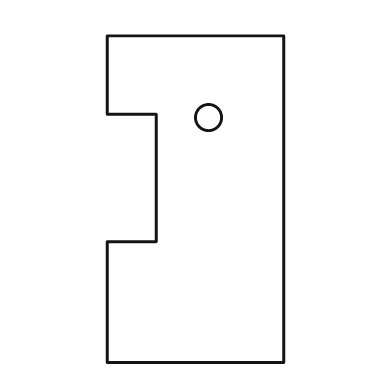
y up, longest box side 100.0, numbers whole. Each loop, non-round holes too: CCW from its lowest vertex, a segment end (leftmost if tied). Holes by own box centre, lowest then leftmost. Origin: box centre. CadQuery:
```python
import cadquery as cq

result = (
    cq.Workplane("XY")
    .moveTo(-27.0, -50.0)
    .lineTo(27.0, -50.0)
    .lineTo(27.0, 50.0)
    .lineTo(-27.0, 50.0)
    .lineTo(-27.0, 26.0)
    .lineTo(-12.0, 26.0)
    .lineTo(-12.0, -13.0)
    .lineTo(-27.0, -13.0)
    .close()
    .moveTo(4.0, 25.0)
    .circle(4.0)
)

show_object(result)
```